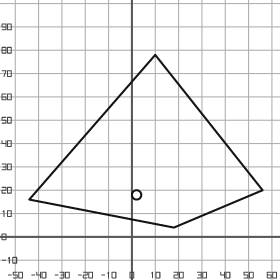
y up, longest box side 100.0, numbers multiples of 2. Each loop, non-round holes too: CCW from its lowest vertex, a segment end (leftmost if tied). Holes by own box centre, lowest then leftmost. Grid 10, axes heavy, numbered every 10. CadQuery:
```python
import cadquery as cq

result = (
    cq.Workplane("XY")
    .moveTo(18.0, 4.0)
    .lineTo(56.0, 20.0)
    .lineTo(10.0, 78.0)
    .lineTo(-44.0, 16.0)
    .close()
    .moveTo(2.0, 18.0)
    .circle(2.0)
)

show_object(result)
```